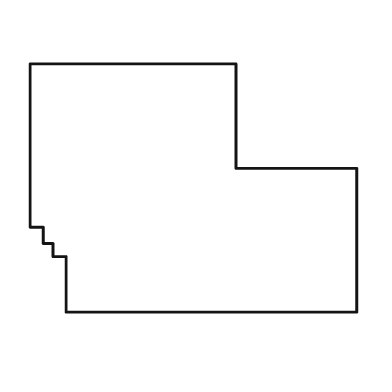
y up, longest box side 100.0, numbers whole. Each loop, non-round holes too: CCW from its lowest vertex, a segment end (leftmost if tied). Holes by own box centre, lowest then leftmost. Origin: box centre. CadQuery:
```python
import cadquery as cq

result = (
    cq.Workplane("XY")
    .moveTo(-39.0, -38.0)
    .lineTo(50.0, -38.0)
    .lineTo(50.0, 6.0)
    .lineTo(13.0, 6.0)
    .lineTo(13.0, 38.0)
    .lineTo(-50.0, 38.0)
    .lineTo(-50.0, -12.0)
    .lineTo(-46.0, -12.0)
    .lineTo(-46.0, -17.0)
    .lineTo(-43.0, -17.0)
    .lineTo(-43.0, -21.0)
    .lineTo(-39.0, -21.0)
    .close()
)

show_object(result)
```